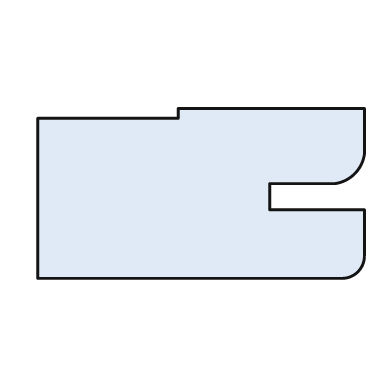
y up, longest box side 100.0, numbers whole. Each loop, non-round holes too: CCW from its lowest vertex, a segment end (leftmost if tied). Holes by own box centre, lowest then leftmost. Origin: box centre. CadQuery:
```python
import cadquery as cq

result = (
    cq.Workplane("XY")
    .moveTo(-50.0, -26.0)
    .lineTo(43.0, -26.0)
    .threePointArc((48.0, -24.0), (50.0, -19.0))
    .lineTo(50.0, -5.0)
    .lineTo(21.0, -5.0)
    .lineTo(21.0, 3.0)
    .lineTo(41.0, 3.0)
    .threePointArc((47.0, 6.0), (50.0, 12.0))
    .lineTo(50.0, 26.0)
    .lineTo(-7.0, 26.0)
    .lineTo(-7.0, 23.0)
    .lineTo(-50.0, 23.0)
    .close()
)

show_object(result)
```